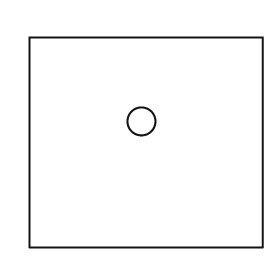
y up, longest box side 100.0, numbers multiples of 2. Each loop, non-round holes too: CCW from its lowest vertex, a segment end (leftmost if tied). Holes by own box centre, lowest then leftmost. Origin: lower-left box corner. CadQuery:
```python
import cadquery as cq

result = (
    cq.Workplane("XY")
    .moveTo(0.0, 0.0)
    .lineTo(100.0, 0.0)
    .lineTo(100.0, 90.0)
    .lineTo(0.0, 90.0)
    .close()
    .moveTo(48.0, 54.0)
    .circle(6.0)
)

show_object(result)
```